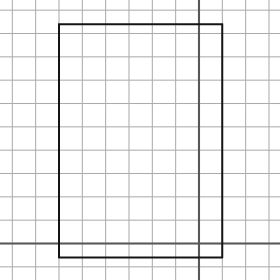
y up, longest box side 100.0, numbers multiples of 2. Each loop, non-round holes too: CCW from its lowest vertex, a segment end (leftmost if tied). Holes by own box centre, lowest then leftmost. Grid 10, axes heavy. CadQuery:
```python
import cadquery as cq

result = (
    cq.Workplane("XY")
    .moveTo(-60.0, -6.0)
    .lineTo(10.0, -6.0)
    .lineTo(10.0, 94.0)
    .lineTo(-60.0, 94.0)
    .close()
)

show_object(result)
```